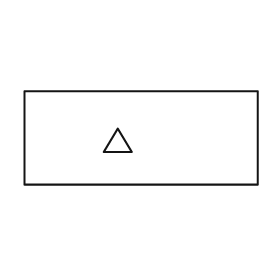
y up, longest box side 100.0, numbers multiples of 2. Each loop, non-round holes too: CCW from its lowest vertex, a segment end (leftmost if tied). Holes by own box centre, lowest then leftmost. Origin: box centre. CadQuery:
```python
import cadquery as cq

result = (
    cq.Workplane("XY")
    .moveTo(-50.0, -20.0)
    .lineTo(50.0, -20.0)
    .lineTo(50.0, 20.0)
    .lineTo(-50.0, 20.0)
    .close()
    .moveTo(-16.0, -6.0)
    .lineTo(-4.0, -6.0)
    .lineTo(-10.0, 4.0)
    .close()
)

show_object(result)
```